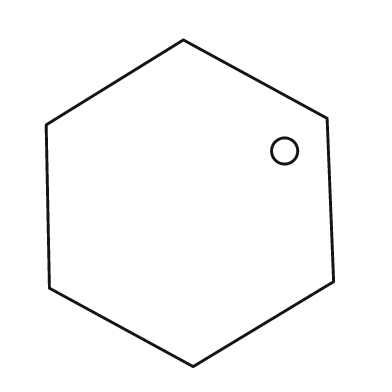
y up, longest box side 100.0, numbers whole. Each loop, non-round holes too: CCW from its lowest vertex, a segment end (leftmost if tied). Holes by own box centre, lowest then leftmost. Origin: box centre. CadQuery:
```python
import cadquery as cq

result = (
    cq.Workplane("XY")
    .moveTo(1.0, -50.0)
    .lineTo(44.0, -24.0)
    .lineTo(42.0, 26.0)
    .lineTo(-2.0, 50.0)
    .lineTo(-44.0, 24.0)
    .lineTo(-43.0, -26.0)
    .close()
    .moveTo(29.0, 16.0)
    .circle(4.0)
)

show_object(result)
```